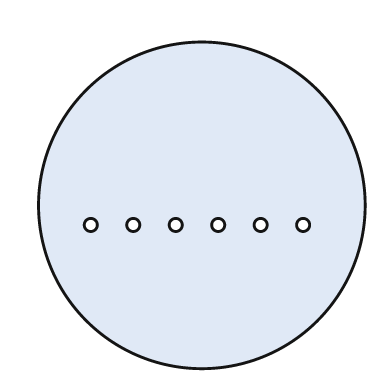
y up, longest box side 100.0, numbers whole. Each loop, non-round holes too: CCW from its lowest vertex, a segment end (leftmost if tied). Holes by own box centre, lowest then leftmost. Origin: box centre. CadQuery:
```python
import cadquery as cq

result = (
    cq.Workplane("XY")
    .moveTo(0.0, 0.0)
    .circle(50.0)
    .moveTo(-34.0, -6.0)
    .circle(2.0)
    .moveTo(-21.0, -6.0)
    .circle(2.0)
    .moveTo(-8.0, -6.0)
    .circle(2.0)
    .moveTo(5.0, -6.0)
    .circle(2.0)
    .moveTo(18.0, -6.0)
    .circle(2.0)
    .moveTo(31.0, -6.0)
    .circle(2.0)
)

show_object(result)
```